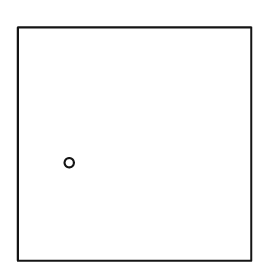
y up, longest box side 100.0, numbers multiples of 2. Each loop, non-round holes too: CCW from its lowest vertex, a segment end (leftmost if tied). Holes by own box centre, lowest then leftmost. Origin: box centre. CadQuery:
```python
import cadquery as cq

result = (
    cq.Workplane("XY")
    .moveTo(-50.0, -50.0)
    .lineTo(50.0, -50.0)
    .lineTo(50.0, 50.0)
    .lineTo(-50.0, 50.0)
    .close()
    .moveTo(-28.0, -8.0)
    .circle(2.0)
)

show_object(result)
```